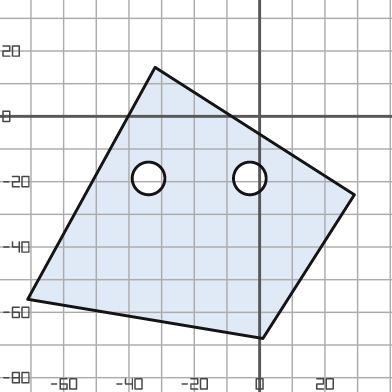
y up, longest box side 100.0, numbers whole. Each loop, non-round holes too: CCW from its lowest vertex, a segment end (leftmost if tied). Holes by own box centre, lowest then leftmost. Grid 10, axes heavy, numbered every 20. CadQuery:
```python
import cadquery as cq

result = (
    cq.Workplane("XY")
    .moveTo(1.0, -68.0)
    .lineTo(29.0, -24.0)
    .lineTo(-32.0, 15.0)
    .lineTo(-71.0, -56.0)
    .close()
    .moveTo(-34.0, -19.0)
    .circle(5.0)
    .moveTo(-3.0, -19.0)
    .circle(5.0)
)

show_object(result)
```